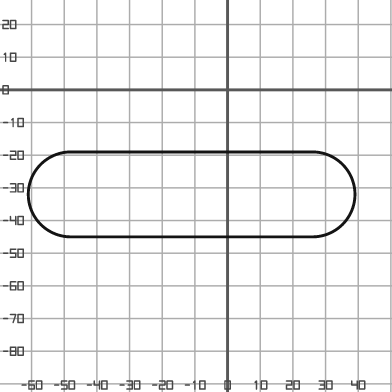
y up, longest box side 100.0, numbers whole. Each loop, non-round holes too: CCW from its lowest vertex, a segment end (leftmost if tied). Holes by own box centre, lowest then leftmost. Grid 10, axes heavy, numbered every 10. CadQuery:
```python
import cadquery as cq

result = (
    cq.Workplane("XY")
    .moveTo(-48.0, -45.0)
    .lineTo(26.0, -45.0)
    .threePointArc((39.0, -32.0), (26.0, -19.0))
    .lineTo(-48.0, -19.0)
    .threePointArc((-61.0, -32.0), (-48.0, -45.0))
    .close()
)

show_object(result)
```